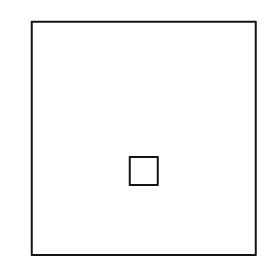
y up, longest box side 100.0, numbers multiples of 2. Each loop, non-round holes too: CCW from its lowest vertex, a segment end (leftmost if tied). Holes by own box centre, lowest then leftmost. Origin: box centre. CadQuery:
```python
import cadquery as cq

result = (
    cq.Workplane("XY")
    .moveTo(-48.0, -50.0)
    .lineTo(48.0, -50.0)
    .lineTo(48.0, 50.0)
    .lineTo(-48.0, 50.0)
    .close()
    .moveTo(-6.0, -20.0)
    .lineTo(6.0, -20.0)
    .lineTo(6.0, -8.0)
    .lineTo(-6.0, -8.0)
    .close()
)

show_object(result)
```